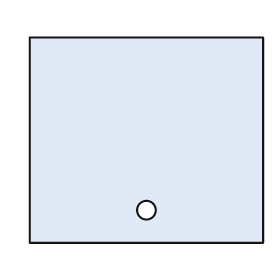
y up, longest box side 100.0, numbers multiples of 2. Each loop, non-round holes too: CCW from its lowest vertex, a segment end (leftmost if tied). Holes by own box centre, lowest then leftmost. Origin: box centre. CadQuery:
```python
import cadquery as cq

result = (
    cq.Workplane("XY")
    .moveTo(-50.0, -44.0)
    .lineTo(50.0, -44.0)
    .lineTo(50.0, 44.0)
    .lineTo(-50.0, 44.0)
    .close()
    .moveTo(0.0, -30.0)
    .circle(4.0)
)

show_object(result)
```